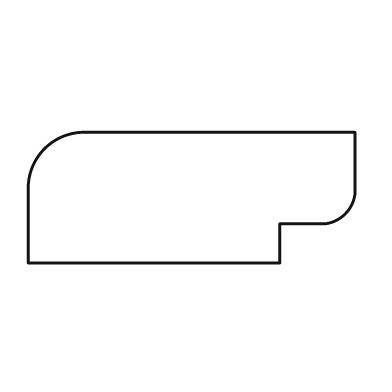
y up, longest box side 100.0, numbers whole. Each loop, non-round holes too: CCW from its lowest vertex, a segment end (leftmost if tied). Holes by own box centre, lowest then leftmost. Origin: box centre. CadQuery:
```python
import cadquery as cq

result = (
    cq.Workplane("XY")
    .moveTo(-50.0, -20.0)
    .lineTo(27.0, -20.0)
    .lineTo(27.0, -8.0)
    .lineTo(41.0, -8.0)
    .threePointArc((47.0, -5.0), (50.0, 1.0))
    .lineTo(50.0, 20.0)
    .lineTo(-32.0, 20.0)
    .threePointArc((-45.0, 15.0), (-50.0, 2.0))
    .close()
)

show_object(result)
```